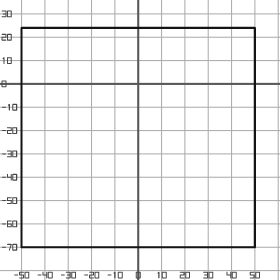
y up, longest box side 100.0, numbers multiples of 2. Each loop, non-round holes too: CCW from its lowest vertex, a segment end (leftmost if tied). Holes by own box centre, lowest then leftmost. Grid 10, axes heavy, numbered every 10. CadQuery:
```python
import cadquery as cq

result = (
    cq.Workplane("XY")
    .moveTo(-50.0, -70.0)
    .lineTo(50.0, -70.0)
    .lineTo(50.0, 24.0)
    .lineTo(-50.0, 24.0)
    .close()
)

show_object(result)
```